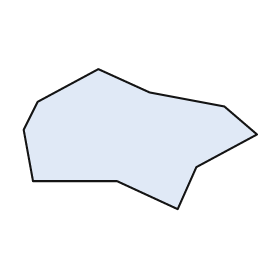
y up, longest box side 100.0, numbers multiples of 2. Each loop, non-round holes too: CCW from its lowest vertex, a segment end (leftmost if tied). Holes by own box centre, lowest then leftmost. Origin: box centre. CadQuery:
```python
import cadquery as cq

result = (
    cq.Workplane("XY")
    .moveTo(16.0, -30.0)
    .lineTo(24.0, -12.0)
    .lineTo(50.0, 2.0)
    .lineTo(36.0, 14.0)
    .lineTo(4.0, 20.0)
    .lineTo(-18.0, 30.0)
    .lineTo(-44.0, 16.0)
    .lineTo(-50.0, 4.0)
    .lineTo(-46.0, -18.0)
    .lineTo(-10.0, -18.0)
    .close()
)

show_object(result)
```